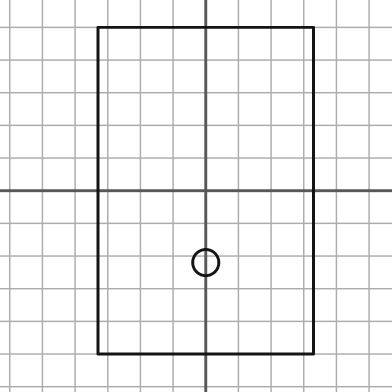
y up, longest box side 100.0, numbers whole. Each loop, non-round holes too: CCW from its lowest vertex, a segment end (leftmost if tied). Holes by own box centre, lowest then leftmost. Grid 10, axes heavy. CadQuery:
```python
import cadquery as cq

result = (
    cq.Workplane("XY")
    .moveTo(-33.0, -50.0)
    .lineTo(33.0, -50.0)
    .lineTo(33.0, 50.0)
    .lineTo(-33.0, 50.0)
    .close()
    .moveTo(0.0, -22.0)
    .circle(4.0)
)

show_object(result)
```